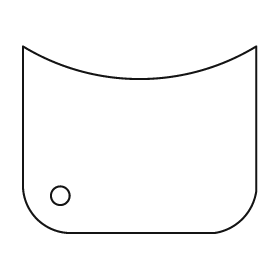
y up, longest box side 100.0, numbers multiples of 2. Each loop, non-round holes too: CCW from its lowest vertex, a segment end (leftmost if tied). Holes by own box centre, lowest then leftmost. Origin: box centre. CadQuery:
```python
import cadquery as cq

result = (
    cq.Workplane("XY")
    .moveTo(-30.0, -40.0)
    .lineTo(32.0, -40.0)
    .threePointArc((44.0, -34.0), (50.0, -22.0))
    .lineTo(50.0, 40.0)
    .threePointArc((0.0, 26.0), (-50.0, 40.0))
    .lineTo(-50.0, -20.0)
    .threePointArc((-44.0, -34.0), (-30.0, -40.0))
    .close()
    .moveTo(-34.0, -24.0)
    .circle(4.0)
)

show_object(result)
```